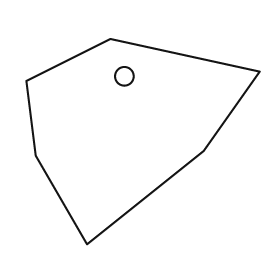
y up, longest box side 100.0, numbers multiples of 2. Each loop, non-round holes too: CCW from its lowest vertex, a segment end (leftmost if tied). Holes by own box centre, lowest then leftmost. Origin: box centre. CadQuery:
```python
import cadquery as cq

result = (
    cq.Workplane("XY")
    .moveTo(-24.0, -44.0)
    .lineTo(26.0, -4.0)
    .lineTo(50.0, 30.0)
    .lineTo(-14.0, 44.0)
    .lineTo(-50.0, 26.0)
    .lineTo(-46.0, -6.0)
    .close()
    .moveTo(-8.0, 28.0)
    .circle(4.0)
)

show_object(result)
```